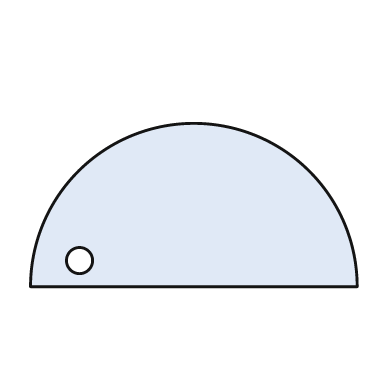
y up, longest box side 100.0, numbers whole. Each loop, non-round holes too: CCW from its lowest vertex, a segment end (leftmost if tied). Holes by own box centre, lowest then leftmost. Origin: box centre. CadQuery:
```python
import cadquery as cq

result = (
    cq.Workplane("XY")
    .moveTo(-50.0, -25.0)
    .lineTo(50.0, -25.0)
    .threePointArc((0.0, 25.0), (-50.0, -25.0))
    .close()
    .moveTo(-35.0, -17.0)
    .circle(4.0)
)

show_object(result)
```